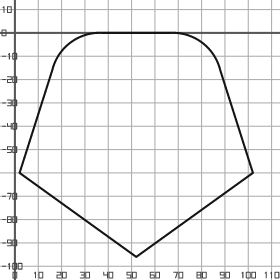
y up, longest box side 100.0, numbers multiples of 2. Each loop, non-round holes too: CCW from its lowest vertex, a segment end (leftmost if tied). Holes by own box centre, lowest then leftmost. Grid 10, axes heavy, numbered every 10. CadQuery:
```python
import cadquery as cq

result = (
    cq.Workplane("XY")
    .moveTo(52.0, -96.0)
    .lineTo(102.0, -60.0)
    .lineTo(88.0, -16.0)
    .threePointArc((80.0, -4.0), (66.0, 0.0))
    .lineTo(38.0, 0.0)
    .threePointArc((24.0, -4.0), (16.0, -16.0))
    .lineTo(2.0, -60.0)
    .close()
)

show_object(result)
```